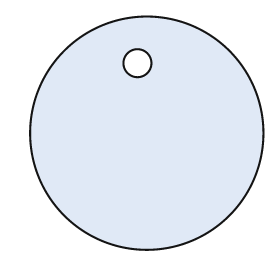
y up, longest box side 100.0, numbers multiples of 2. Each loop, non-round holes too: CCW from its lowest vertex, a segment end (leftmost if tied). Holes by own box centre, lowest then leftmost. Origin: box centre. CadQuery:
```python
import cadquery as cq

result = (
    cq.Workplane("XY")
    .moveTo(0.0, 0.0)
    .circle(50.0)
    .moveTo(-4.0, 30.0)
    .circle(6.0)
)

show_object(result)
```